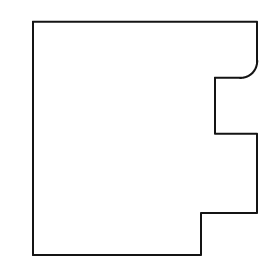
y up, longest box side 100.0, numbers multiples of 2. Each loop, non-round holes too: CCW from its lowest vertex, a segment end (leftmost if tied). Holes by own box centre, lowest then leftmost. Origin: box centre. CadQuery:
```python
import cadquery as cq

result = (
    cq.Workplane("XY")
    .moveTo(-48.0, -50.0)
    .lineTo(24.0, -50.0)
    .lineTo(24.0, -32.0)
    .lineTo(48.0, -32.0)
    .lineTo(48.0, 2.0)
    .lineTo(30.0, 2.0)
    .lineTo(30.0, 26.0)
    .lineTo(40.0, 26.0)
    .threePointArc((46.0, 28.0), (48.0, 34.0))
    .lineTo(48.0, 50.0)
    .lineTo(-48.0, 50.0)
    .close()
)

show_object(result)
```